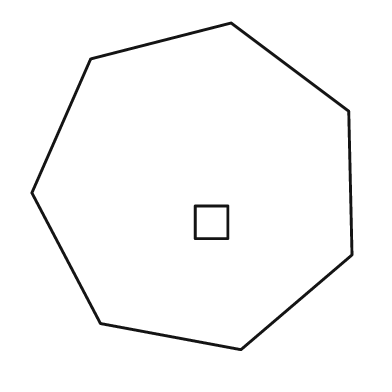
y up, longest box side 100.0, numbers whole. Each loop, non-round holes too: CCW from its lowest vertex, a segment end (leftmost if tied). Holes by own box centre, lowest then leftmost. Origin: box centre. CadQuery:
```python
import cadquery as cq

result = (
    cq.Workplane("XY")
    .moveTo(15.0, -50.0)
    .lineTo(49.0, -21.0)
    .lineTo(48.0, 23.0)
    .lineTo(12.0, 50.0)
    .lineTo(-31.0, 39.0)
    .lineTo(-49.0, -2.0)
    .lineTo(-28.0, -42.0)
    .close()
    .moveTo(1.0, -16.0)
    .lineTo(11.0, -16.0)
    .lineTo(11.0, -6.0)
    .lineTo(1.0, -6.0)
    .close()
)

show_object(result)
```